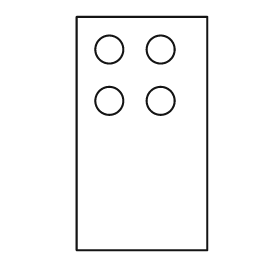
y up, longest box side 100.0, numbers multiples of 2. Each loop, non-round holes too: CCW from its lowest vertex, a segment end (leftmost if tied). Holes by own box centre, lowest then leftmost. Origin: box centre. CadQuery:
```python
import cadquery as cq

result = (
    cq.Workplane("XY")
    .moveTo(-28.0, -50.0)
    .lineTo(28.0, -50.0)
    .lineTo(28.0, 50.0)
    .lineTo(-28.0, 50.0)
    .close()
    .moveTo(-14.0, 14.0)
    .circle(6.0)
    .moveTo(8.0, 14.0)
    .circle(6.0)
    .moveTo(-14.0, 36.0)
    .circle(6.0)
    .moveTo(8.0, 36.0)
    .circle(6.0)
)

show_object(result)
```